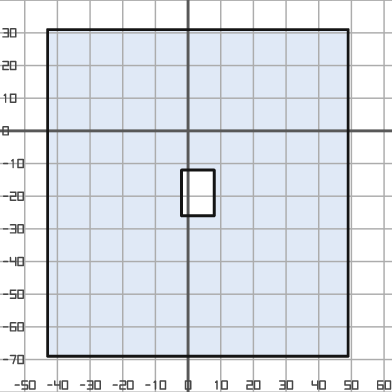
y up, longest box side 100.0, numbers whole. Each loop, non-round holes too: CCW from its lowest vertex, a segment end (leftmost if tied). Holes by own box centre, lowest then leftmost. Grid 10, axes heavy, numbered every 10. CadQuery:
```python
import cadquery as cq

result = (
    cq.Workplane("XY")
    .moveTo(-43.0, -69.0)
    .lineTo(49.0, -69.0)
    .lineTo(49.0, 31.0)
    .lineTo(-43.0, 31.0)
    .close()
    .moveTo(-2.0, -26.0)
    .lineTo(8.0, -26.0)
    .lineTo(8.0, -12.0)
    .lineTo(-2.0, -12.0)
    .close()
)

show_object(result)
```